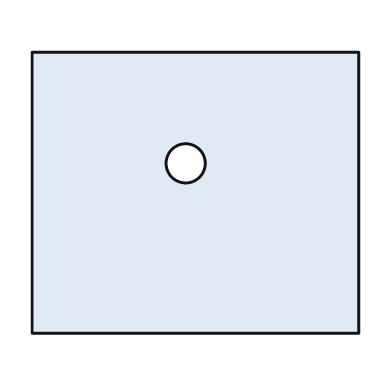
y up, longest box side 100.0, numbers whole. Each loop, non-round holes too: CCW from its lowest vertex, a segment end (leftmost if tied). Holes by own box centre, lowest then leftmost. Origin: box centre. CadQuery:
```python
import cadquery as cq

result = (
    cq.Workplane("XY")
    .moveTo(-50.0, -43.0)
    .lineTo(50.0, -43.0)
    .lineTo(50.0, 43.0)
    .lineTo(-50.0, 43.0)
    .close()
    .moveTo(-3.0, 9.0)
    .circle(6.0)
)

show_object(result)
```